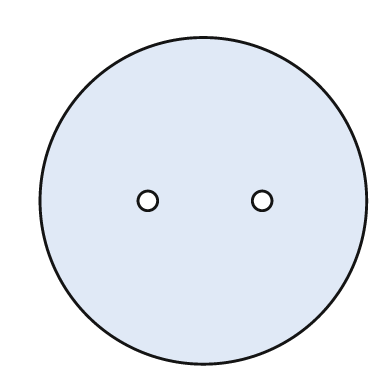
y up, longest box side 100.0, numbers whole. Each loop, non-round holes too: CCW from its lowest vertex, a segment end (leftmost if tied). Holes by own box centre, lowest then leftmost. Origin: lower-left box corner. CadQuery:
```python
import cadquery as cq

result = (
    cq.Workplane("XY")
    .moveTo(50.0, 50.0)
    .circle(50.0)
    .moveTo(33.0, 50.0)
    .circle(3.0)
    .moveTo(68.0, 50.0)
    .circle(3.0)
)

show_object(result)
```